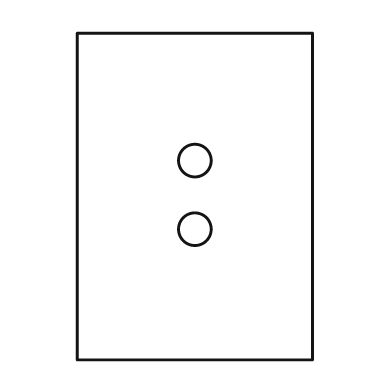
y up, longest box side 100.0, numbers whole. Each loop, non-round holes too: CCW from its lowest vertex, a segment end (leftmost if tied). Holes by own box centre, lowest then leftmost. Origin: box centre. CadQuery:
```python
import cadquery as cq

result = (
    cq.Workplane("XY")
    .moveTo(-36.0, -50.0)
    .lineTo(36.0, -50.0)
    .lineTo(36.0, 50.0)
    .lineTo(-36.0, 50.0)
    .close()
    .moveTo(0.0, -10.0)
    .circle(5.0)
    .moveTo(0.0, 11.0)
    .circle(5.0)
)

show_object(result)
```